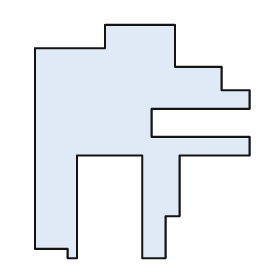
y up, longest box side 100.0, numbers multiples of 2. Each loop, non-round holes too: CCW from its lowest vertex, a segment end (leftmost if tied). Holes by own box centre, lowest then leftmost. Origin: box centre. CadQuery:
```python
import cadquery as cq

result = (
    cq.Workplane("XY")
    .moveTo(-32.0, -50.0)
    .lineTo(-28.0, -50.0)
    .lineTo(-28.0, -6.0)
    .lineTo(0.0, -6.0)
    .lineTo(0.0, -50.0)
    .lineTo(10.0, -50.0)
    .lineTo(10.0, -32.0)
    .lineTo(16.0, -32.0)
    .lineTo(16.0, -6.0)
    .lineTo(46.0, -6.0)
    .lineTo(46.0, 2.0)
    .lineTo(4.0, 2.0)
    .lineTo(4.0, 14.0)
    .lineTo(46.0, 14.0)
    .lineTo(46.0, 22.0)
    .lineTo(34.0, 22.0)
    .lineTo(34.0, 32.0)
    .lineTo(14.0, 32.0)
    .lineTo(14.0, 50.0)
    .lineTo(-16.0, 50.0)
    .lineTo(-16.0, 40.0)
    .lineTo(-46.0, 40.0)
    .lineTo(-46.0, -46.0)
    .lineTo(-32.0, -46.0)
    .close()
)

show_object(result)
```